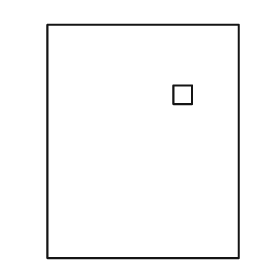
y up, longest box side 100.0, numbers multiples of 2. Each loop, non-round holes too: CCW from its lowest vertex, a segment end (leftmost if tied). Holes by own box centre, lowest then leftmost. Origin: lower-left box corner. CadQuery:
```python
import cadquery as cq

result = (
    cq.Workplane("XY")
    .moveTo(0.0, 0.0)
    .lineTo(82.0, 0.0)
    .lineTo(82.0, 100.0)
    .lineTo(0.0, 100.0)
    .close()
    .moveTo(54.0, 66.0)
    .lineTo(62.0, 66.0)
    .lineTo(62.0, 74.0)
    .lineTo(54.0, 74.0)
    .close()
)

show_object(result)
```